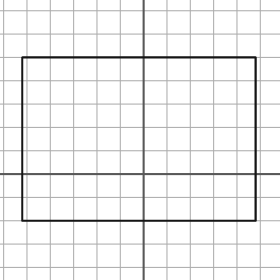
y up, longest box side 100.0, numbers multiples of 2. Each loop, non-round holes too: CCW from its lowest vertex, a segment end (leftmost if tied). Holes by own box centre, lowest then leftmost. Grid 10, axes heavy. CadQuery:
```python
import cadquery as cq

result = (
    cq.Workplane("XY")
    .moveTo(-52.0, -20.0)
    .lineTo(48.0, -20.0)
    .lineTo(48.0, 50.0)
    .lineTo(-52.0, 50.0)
    .close()
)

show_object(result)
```